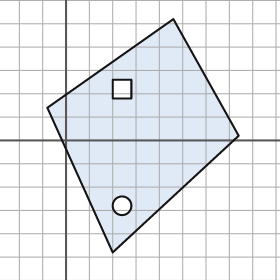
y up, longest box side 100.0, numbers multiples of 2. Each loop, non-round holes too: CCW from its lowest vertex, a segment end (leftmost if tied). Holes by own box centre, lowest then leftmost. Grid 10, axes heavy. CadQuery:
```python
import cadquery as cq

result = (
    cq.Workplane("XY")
    .moveTo(20.0, -48.0)
    .lineTo(74.0, 2.0)
    .lineTo(46.0, 52.0)
    .lineTo(-8.0, 14.0)
    .close()
    .moveTo(24.0, -28.0)
    .circle(4.0)
    .moveTo(20.0, 18.0)
    .lineTo(28.0, 18.0)
    .lineTo(28.0, 26.0)
    .lineTo(20.0, 26.0)
    .close()
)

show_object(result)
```